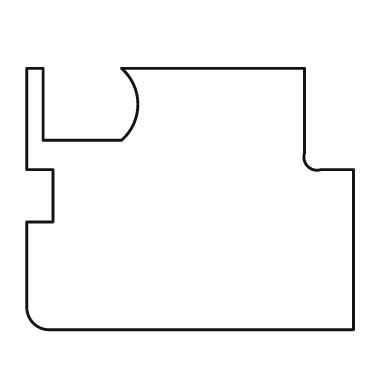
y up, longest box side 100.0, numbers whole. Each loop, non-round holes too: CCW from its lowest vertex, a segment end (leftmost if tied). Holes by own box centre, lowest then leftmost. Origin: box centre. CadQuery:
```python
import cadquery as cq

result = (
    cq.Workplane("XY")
    .moveTo(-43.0, -40.0)
    .lineTo(50.0, -40.0)
    .lineTo(50.0, 9.0)
    .lineTo(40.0, 9.0)
    .threePointArc((36.0, 10.0), (35.0, 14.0))
    .lineTo(35.0, 40.0)
    .lineTo(-21.0, 40.0)
    .threePointArc((-16.0, 29.0), (-21.0, 18.0))
    .lineTo(-45.0, 18.0)
    .lineTo(-45.0, 40.0)
    .lineTo(-50.0, 40.0)
    .lineTo(-50.0, 9.0)
    .lineTo(-42.0, 9.0)
    .lineTo(-42.0, -7.0)
    .lineTo(-50.0, -7.0)
    .lineTo(-50.0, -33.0)
    .threePointArc((-48.0, -38.0), (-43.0, -40.0))
    .close()
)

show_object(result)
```